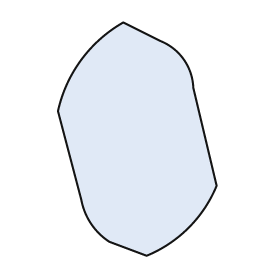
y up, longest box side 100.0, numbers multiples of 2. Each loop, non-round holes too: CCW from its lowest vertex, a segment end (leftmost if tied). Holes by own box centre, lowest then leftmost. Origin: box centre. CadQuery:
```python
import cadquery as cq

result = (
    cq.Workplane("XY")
    .moveTo(4.0, -50.0)
    .threePointArc((22.0, -38.0), (34.0, -20.0))
    .lineTo(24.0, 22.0)
    .threePointArc((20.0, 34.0), (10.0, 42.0))
    .lineTo(-6.0, 50.0)
    .threePointArc((-24.0, 34.0), (-34.0, 12.0))
    .lineTo(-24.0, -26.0)
    .threePointArc((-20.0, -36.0), (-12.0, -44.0))
    .close()
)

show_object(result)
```